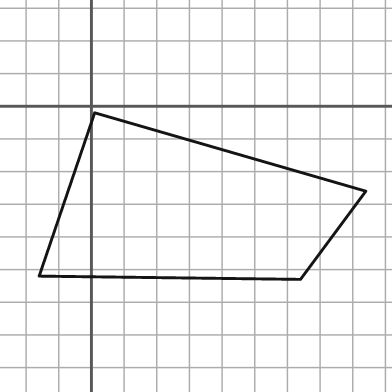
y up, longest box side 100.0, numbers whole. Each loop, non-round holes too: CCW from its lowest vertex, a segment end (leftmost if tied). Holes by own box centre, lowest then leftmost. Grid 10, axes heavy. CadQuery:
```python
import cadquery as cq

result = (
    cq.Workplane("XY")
    .moveTo(64.0, -53.0)
    .lineTo(84.0, -26.0)
    .lineTo(1.0, -2.0)
    .lineTo(-16.0, -52.0)
    .close()
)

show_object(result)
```